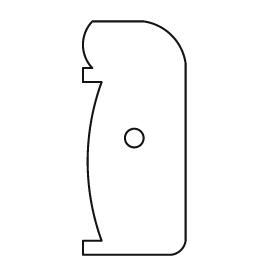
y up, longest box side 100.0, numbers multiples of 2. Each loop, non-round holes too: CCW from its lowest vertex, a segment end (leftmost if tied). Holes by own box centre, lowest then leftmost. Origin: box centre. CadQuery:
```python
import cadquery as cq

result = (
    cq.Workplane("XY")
    .moveTo(-22.0, -50.0)
    .lineTo(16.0, -50.0)
    .threePointArc((20.0, -48.0), (22.0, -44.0))
    .lineTo(22.0, 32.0)
    .threePointArc((16.0, 44.0), (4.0, 50.0))
    .lineTo(-18.0, 50.0)
    .threePointArc((-22.0, 40.0), (-18.0, 30.0))
    .lineTo(-22.0, 30.0)
    .lineTo(-22.0, 24.0)
    .lineTo(-14.0, 24.0)
    .threePointArc((-20.0, -10.0), (-14.0, -44.0))
    .lineTo(-22.0, -44.0)
    .close()
    .moveTo(0.0, 0.0)
    .circle(4.0)
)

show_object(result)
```